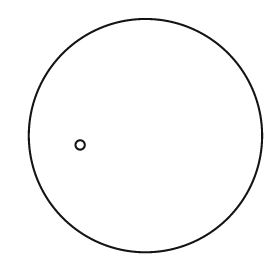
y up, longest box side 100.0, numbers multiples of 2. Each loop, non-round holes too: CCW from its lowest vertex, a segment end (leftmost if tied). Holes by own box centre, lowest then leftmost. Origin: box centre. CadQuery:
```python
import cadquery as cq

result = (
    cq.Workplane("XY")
    .moveTo(0.0, 0.0)
    .circle(50.0)
    .moveTo(-28.0, -4.0)
    .circle(2.0)
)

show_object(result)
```